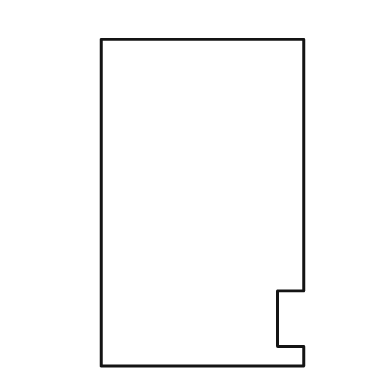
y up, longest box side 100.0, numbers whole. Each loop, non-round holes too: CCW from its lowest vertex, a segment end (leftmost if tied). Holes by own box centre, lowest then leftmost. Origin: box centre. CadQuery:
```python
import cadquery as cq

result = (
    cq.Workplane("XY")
    .moveTo(-31.0, -50.0)
    .lineTo(31.0, -50.0)
    .lineTo(31.0, -44.0)
    .lineTo(23.0, -44.0)
    .lineTo(23.0, -27.0)
    .lineTo(31.0, -27.0)
    .lineTo(31.0, 50.0)
    .lineTo(-31.0, 50.0)
    .close()
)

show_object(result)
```